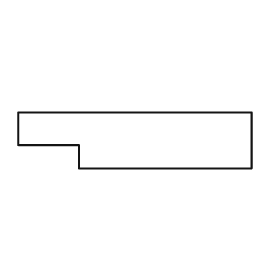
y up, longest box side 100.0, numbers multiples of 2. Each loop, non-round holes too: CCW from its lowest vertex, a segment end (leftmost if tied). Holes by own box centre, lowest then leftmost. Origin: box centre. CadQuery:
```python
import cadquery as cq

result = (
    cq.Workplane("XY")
    .moveTo(-24.0, -12.0)
    .lineTo(50.0, -12.0)
    .lineTo(50.0, 12.0)
    .lineTo(-50.0, 12.0)
    .lineTo(-50.0, -2.0)
    .lineTo(-24.0, -2.0)
    .close()
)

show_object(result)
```